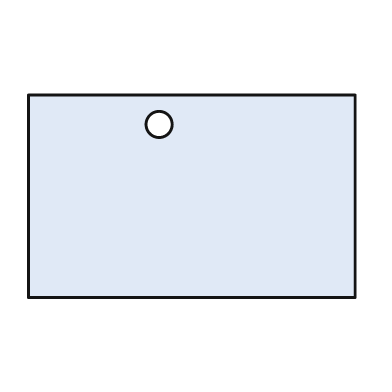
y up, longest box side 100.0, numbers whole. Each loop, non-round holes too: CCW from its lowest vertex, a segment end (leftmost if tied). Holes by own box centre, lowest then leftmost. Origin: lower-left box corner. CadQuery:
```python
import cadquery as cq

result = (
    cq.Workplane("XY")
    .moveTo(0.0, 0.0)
    .lineTo(100.0, 0.0)
    .lineTo(100.0, 62.0)
    .lineTo(0.0, 62.0)
    .close()
    .moveTo(40.0, 53.0)
    .circle(4.0)
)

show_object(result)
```